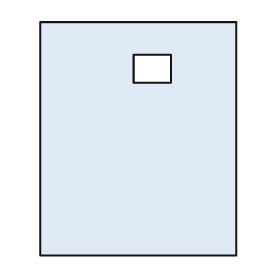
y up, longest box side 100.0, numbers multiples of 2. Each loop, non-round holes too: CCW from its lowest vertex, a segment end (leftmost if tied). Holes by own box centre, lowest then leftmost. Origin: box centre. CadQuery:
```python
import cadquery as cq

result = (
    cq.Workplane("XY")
    .moveTo(-42.0, -50.0)
    .lineTo(42.0, -50.0)
    .lineTo(42.0, 50.0)
    .lineTo(-42.0, 50.0)
    .close()
    .moveTo(-2.0, 24.0)
    .lineTo(14.0, 24.0)
    .lineTo(14.0, 36.0)
    .lineTo(-2.0, 36.0)
    .close()
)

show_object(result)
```